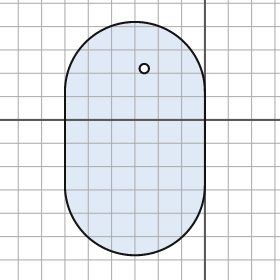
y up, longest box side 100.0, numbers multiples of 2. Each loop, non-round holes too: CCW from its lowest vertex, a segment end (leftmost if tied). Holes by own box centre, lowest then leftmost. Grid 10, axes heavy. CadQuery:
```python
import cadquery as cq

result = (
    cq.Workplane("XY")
    .moveTo(-60.0, -28.0)
    .threePointArc((-30.0, -58.0), (0.0, -28.0))
    .lineTo(0.0, 12.0)
    .threePointArc((-30.0, 42.0), (-60.0, 12.0))
    .close()
    .moveTo(-26.0, 22.0)
    .circle(2.0)
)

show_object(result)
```